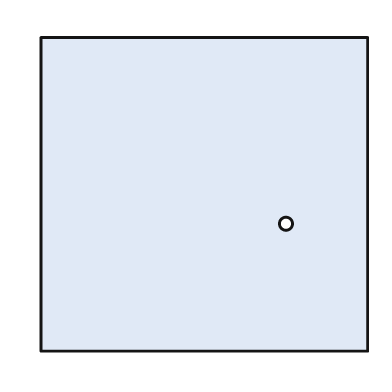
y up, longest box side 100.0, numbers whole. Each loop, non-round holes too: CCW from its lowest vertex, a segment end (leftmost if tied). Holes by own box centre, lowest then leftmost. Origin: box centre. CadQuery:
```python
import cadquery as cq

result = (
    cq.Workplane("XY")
    .moveTo(-50.0, -48.0)
    .lineTo(50.0, -48.0)
    .lineTo(50.0, 48.0)
    .lineTo(-50.0, 48.0)
    .close()
    .moveTo(25.0, -9.0)
    .circle(2.0)
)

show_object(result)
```